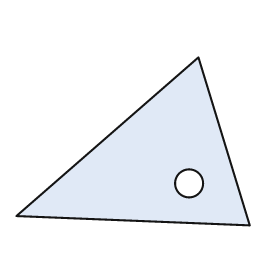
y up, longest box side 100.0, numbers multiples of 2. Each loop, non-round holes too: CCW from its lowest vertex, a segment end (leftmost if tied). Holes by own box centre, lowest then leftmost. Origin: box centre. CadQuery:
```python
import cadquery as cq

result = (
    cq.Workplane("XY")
    .moveTo(50.0, -36.0)
    .lineTo(28.0, 36.0)
    .lineTo(-50.0, -32.0)
    .close()
    .moveTo(24.0, -18.0)
    .circle(6.0)
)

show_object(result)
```